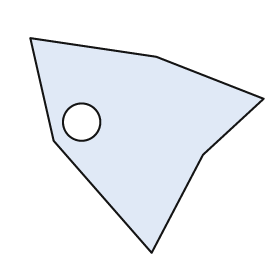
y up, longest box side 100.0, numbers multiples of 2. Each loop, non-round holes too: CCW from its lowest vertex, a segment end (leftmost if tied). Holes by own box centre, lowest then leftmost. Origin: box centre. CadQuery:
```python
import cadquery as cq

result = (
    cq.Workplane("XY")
    .moveTo(2.0, -46.0)
    .lineTo(24.0, -4.0)
    .lineTo(50.0, 20.0)
    .lineTo(4.0, 38.0)
    .lineTo(-50.0, 46.0)
    .lineTo(-40.0, 2.0)
    .close()
    .moveTo(-28.0, 10.0)
    .circle(8.0)
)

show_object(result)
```